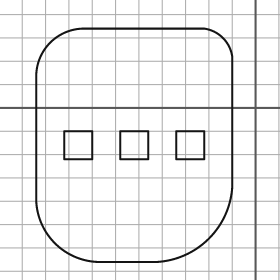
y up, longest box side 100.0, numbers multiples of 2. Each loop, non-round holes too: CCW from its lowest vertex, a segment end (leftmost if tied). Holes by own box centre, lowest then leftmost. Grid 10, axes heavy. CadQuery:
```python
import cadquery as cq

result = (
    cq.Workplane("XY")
    .moveTo(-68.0, -66.0)
    .lineTo(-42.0, -66.0)
    .threePointArc((-20.0, -56.0), (-10.0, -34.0))
    .lineTo(-10.0, 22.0)
    .threePointArc((-14.0, 30.0), (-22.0, 34.0))
    .lineTo(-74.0, 34.0)
    .threePointArc((-88.0, 28.0), (-94.0, 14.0))
    .lineTo(-94.0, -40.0)
    .threePointArc((-86.0, -58.0), (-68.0, -66.0))
    .close()
    .moveTo(-82.0, -22.0)
    .lineTo(-70.0, -22.0)
    .lineTo(-70.0, -10.0)
    .lineTo(-82.0, -10.0)
    .close()
    .moveTo(-58.0, -22.0)
    .lineTo(-46.0, -22.0)
    .lineTo(-46.0, -10.0)
    .lineTo(-58.0, -10.0)
    .close()
    .moveTo(-34.0, -22.0)
    .lineTo(-22.0, -22.0)
    .lineTo(-22.0, -10.0)
    .lineTo(-34.0, -10.0)
    .close()
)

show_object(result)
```